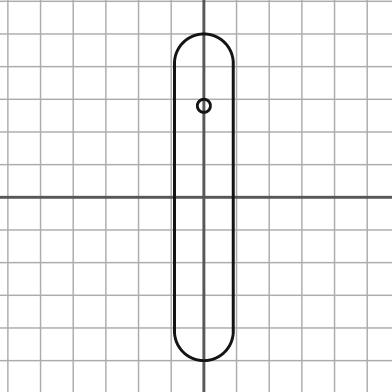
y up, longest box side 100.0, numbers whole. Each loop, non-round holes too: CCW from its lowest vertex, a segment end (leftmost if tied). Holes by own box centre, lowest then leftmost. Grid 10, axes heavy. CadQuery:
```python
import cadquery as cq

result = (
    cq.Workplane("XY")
    .moveTo(-9.0, -41.0)
    .threePointArc((0.0, -50.0), (9.0, -41.0))
    .lineTo(9.0, 41.0)
    .threePointArc((0.0, 50.0), (-9.0, 41.0))
    .close()
    .moveTo(0.0, 28.0)
    .circle(2.0)
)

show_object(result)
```